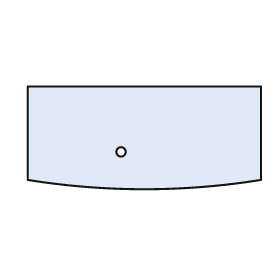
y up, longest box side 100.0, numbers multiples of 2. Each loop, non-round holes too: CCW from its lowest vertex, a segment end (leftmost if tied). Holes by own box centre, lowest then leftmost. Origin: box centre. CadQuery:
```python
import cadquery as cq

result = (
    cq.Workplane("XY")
    .moveTo(-50.0, -18.0)
    .threePointArc((0.0, -22.0), (50.0, -18.0))
    .lineTo(50.0, 22.0)
    .lineTo(-50.0, 22.0)
    .close()
    .moveTo(-10.0, -6.0)
    .circle(2.0)
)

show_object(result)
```